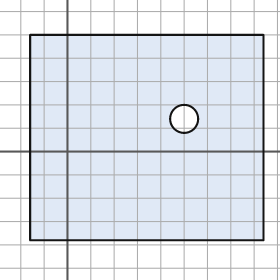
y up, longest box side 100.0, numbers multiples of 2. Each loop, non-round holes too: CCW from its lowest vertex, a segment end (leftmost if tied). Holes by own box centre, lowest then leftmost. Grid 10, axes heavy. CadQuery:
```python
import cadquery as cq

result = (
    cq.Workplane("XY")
    .moveTo(-16.0, -38.0)
    .lineTo(84.0, -38.0)
    .lineTo(84.0, 50.0)
    .lineTo(-16.0, 50.0)
    .close()
    .moveTo(50.0, 14.0)
    .circle(6.0)
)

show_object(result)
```